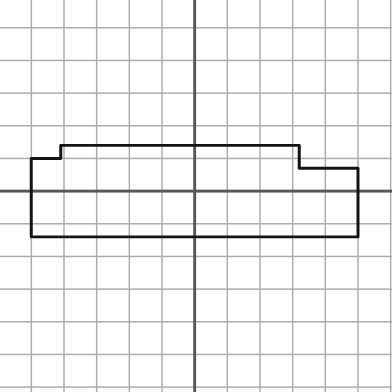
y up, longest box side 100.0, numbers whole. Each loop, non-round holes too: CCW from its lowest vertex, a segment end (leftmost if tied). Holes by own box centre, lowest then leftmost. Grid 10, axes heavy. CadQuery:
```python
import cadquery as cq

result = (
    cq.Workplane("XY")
    .moveTo(-50.0, -14.0)
    .lineTo(50.0, -14.0)
    .lineTo(50.0, 7.0)
    .lineTo(32.0, 7.0)
    .lineTo(32.0, 14.0)
    .lineTo(-41.0, 14.0)
    .lineTo(-41.0, 10.0)
    .lineTo(-50.0, 10.0)
    .close()
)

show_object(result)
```